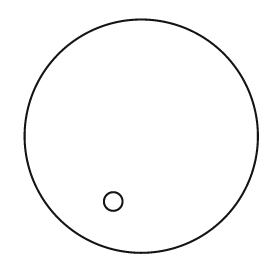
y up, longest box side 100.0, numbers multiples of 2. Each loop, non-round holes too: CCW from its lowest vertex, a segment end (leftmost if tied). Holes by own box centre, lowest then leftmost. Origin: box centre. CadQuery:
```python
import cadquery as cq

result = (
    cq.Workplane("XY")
    .moveTo(0.0, 0.0)
    .circle(50.0)
    .moveTo(-12.0, -28.0)
    .circle(4.0)
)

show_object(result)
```